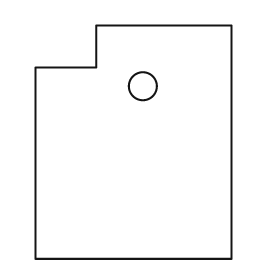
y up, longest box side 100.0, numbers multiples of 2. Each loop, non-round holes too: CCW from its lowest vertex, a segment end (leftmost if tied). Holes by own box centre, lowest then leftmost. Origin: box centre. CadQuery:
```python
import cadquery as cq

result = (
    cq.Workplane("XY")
    .moveTo(-42.0, -50.0)
    .lineTo(42.0, -50.0)
    .lineTo(42.0, 50.0)
    .lineTo(-16.0, 50.0)
    .lineTo(-16.0, 32.0)
    .lineTo(-42.0, 32.0)
    .close()
    .moveTo(4.0, 24.0)
    .circle(6.0)
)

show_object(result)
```